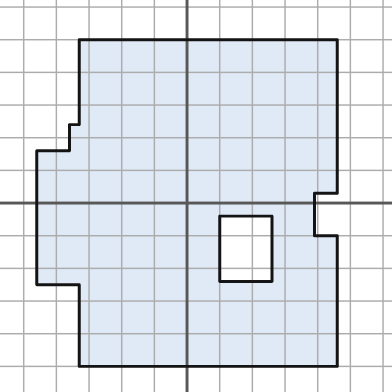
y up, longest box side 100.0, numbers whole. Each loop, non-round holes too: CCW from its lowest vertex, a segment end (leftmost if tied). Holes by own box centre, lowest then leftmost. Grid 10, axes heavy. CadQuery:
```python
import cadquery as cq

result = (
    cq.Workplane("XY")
    .moveTo(-33.0, -50.0)
    .lineTo(46.0, -50.0)
    .lineTo(46.0, -10.0)
    .lineTo(39.0, -10.0)
    .lineTo(39.0, 3.0)
    .lineTo(46.0, 3.0)
    .lineTo(46.0, 50.0)
    .lineTo(-33.0, 50.0)
    .lineTo(-33.0, 24.0)
    .lineTo(-36.0, 24.0)
    .lineTo(-36.0, 16.0)
    .lineTo(-46.0, 16.0)
    .lineTo(-46.0, -25.0)
    .lineTo(-33.0, -25.0)
    .close()
    .moveTo(10.0, -24.0)
    .lineTo(26.0, -24.0)
    .lineTo(26.0, -4.0)
    .lineTo(10.0, -4.0)
    .close()
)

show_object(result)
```